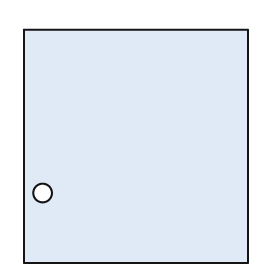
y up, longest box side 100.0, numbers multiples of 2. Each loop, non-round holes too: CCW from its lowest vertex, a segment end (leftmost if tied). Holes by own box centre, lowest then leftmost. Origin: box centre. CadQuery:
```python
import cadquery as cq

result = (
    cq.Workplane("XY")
    .moveTo(-48.0, -50.0)
    .lineTo(48.0, -50.0)
    .lineTo(48.0, 50.0)
    .lineTo(-48.0, 50.0)
    .close()
    .moveTo(-40.0, -20.0)
    .circle(4.0)
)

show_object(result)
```